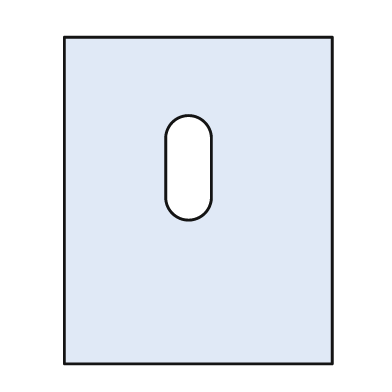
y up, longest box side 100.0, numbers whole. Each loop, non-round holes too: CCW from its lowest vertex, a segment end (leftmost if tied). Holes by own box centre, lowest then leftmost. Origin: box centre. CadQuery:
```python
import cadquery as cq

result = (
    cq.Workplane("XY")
    .moveTo(-41.0, -50.0)
    .lineTo(41.0, -50.0)
    .lineTo(41.0, 50.0)
    .lineTo(-41.0, 50.0)
    .close()
    .moveTo(-10.0, 1.0)
    .threePointArc((-3.0, -6.0), (4.0, 1.0))
    .lineTo(4.0, 19.0)
    .threePointArc((-3.0, 26.0), (-10.0, 19.0))
    .close()
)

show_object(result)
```